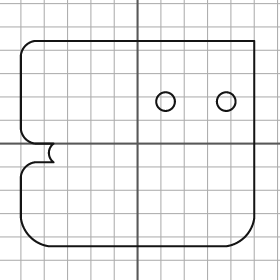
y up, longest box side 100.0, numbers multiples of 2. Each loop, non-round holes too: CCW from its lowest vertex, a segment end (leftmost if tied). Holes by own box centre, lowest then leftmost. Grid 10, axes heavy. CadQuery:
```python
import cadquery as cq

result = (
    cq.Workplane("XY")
    .moveTo(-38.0, -44.0)
    .lineTo(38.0, -44.0)
    .threePointArc((46.0, -40.0), (50.0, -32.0))
    .lineTo(50.0, 44.0)
    .lineTo(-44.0, 44.0)
    .threePointArc((-48.0, 42.0), (-50.0, 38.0))
    .lineTo(-50.0, 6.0)
    .threePointArc((-48.0, 2.0), (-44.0, 0.0))
    .lineTo(-36.0, 0.0)
    .threePointArc((-38.0, -4.0), (-36.0, -8.0))
    .lineTo(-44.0, -8.0)
    .threePointArc((-48.0, -10.0), (-50.0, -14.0))
    .lineTo(-50.0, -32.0)
    .threePointArc((-46.0, -40.0), (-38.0, -44.0))
    .close()
    .moveTo(12.0, 18.0)
    .circle(4.0)
    .moveTo(38.0, 18.0)
    .circle(4.0)
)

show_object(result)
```